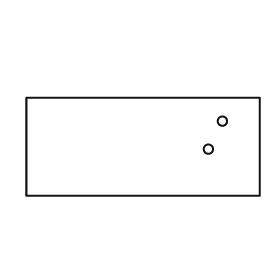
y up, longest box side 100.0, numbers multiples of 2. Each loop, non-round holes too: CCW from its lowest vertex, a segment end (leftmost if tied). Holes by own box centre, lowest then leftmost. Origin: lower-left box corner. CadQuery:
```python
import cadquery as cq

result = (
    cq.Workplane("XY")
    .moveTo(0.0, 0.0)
    .lineTo(100.0, 0.0)
    .lineTo(100.0, 42.0)
    .lineTo(0.0, 42.0)
    .close()
    .moveTo(78.0, 20.0)
    .circle(2.0)
    .moveTo(84.0, 32.0)
    .circle(2.0)
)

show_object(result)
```